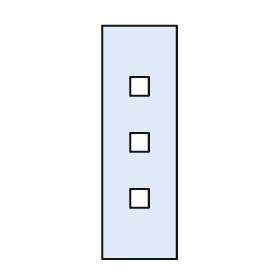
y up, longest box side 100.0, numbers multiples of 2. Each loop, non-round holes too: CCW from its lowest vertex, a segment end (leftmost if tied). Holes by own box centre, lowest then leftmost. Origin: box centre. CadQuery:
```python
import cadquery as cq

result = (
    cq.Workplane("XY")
    .moveTo(-16.0, -50.0)
    .lineTo(16.0, -50.0)
    .lineTo(16.0, 50.0)
    .lineTo(-16.0, 50.0)
    .close()
    .moveTo(-4.0, -28.0)
    .lineTo(4.0, -28.0)
    .lineTo(4.0, -20.0)
    .lineTo(-4.0, -20.0)
    .close()
    .moveTo(-4.0, -4.0)
    .lineTo(4.0, -4.0)
    .lineTo(4.0, 4.0)
    .lineTo(-4.0, 4.0)
    .close()
    .moveTo(-4.0, 20.0)
    .lineTo(4.0, 20.0)
    .lineTo(4.0, 28.0)
    .lineTo(-4.0, 28.0)
    .close()
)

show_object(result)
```